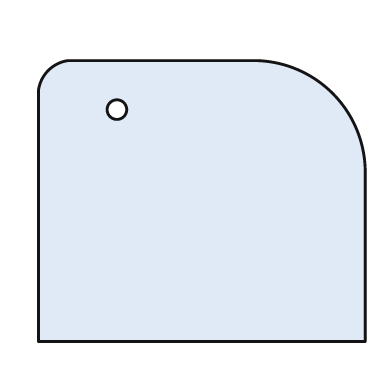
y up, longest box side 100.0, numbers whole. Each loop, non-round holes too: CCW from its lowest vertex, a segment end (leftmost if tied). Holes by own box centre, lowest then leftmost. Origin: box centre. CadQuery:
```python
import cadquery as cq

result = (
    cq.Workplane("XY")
    .moveTo(-50.0, -43.0)
    .lineTo(50.0, -43.0)
    .lineTo(50.0, 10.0)
    .threePointArc((40.0, 33.0), (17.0, 43.0))
    .lineTo(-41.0, 43.0)
    .threePointArc((-47.0, 40.0), (-50.0, 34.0))
    .close()
    .moveTo(-26.0, 28.0)
    .circle(3.0)
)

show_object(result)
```